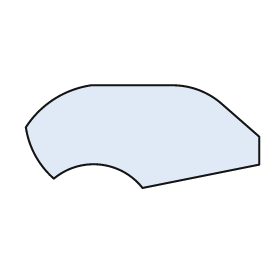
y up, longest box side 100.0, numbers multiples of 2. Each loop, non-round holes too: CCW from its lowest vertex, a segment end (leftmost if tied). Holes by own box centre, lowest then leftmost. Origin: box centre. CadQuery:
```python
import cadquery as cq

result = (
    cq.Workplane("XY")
    .moveTo(0.0, -22.0)
    .lineTo(50.0, -12.0)
    .lineTo(50.0, 0.0)
    .lineTo(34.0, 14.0)
    .threePointArc((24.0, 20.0), (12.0, 22.0))
    .lineTo(-22.0, 22.0)
    .threePointArc((-38.0, 16.0), (-50.0, 4.0))
    .threePointArc((-46.0, -8.0), (-38.0, -18.0))
    .threePointArc((-18.0, -12.0), (0.0, -22.0))
    .close()
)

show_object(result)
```